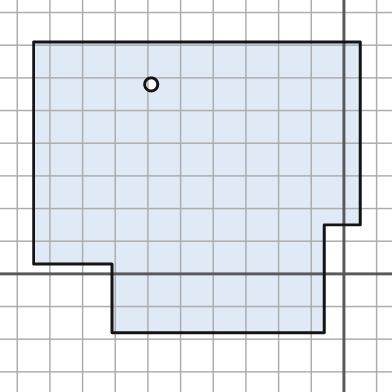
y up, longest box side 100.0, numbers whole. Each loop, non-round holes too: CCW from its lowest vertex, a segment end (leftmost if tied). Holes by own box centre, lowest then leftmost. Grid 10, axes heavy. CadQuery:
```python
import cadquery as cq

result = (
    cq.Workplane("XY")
    .moveTo(-71.0, -18.0)
    .lineTo(-6.0, -18.0)
    .lineTo(-6.0, 15.0)
    .lineTo(5.0, 15.0)
    .lineTo(5.0, 71.0)
    .lineTo(-95.0, 71.0)
    .lineTo(-95.0, 3.0)
    .lineTo(-71.0, 3.0)
    .close()
    .moveTo(-59.0, 58.0)
    .circle(2.0)
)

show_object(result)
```